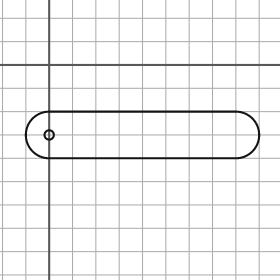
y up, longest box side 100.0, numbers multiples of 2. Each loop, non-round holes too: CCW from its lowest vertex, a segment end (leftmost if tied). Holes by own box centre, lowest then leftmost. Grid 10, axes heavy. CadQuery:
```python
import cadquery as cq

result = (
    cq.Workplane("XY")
    .moveTo(0.0, -40.0)
    .lineTo(80.0, -40.0)
    .threePointArc((90.0, -30.0), (80.0, -20.0))
    .lineTo(0.0, -20.0)
    .threePointArc((-10.0, -30.0), (0.0, -40.0))
    .close()
    .moveTo(0.0, -30.0)
    .circle(2.0)
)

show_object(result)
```